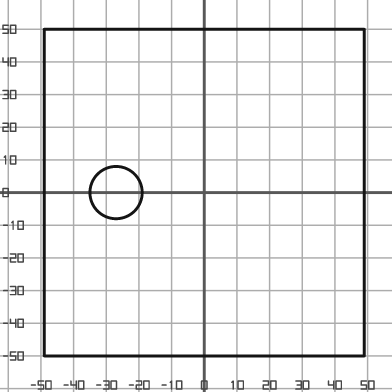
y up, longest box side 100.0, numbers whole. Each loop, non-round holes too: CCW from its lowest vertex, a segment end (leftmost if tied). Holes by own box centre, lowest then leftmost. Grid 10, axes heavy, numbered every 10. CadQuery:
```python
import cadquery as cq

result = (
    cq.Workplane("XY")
    .moveTo(-49.0, -50.0)
    .lineTo(49.0, -50.0)
    .lineTo(49.0, 50.0)
    .lineTo(-49.0, 50.0)
    .close()
    .moveTo(-27.0, 0.0)
    .circle(8.0)
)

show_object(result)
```